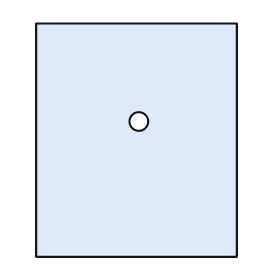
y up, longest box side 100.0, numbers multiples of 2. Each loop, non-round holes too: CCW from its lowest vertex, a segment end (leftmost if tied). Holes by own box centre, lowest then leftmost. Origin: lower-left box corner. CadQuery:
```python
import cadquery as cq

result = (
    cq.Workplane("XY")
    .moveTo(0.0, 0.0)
    .lineTo(86.0, 0.0)
    .lineTo(86.0, 100.0)
    .lineTo(0.0, 100.0)
    .close()
    .moveTo(44.0, 58.0)
    .circle(4.0)
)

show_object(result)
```